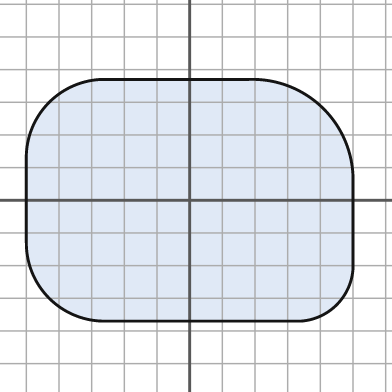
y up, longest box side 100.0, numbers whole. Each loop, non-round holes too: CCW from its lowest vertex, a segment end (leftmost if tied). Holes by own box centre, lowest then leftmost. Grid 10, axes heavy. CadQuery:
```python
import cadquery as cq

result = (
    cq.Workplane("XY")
    .moveTo(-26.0, -37.0)
    .lineTo(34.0, -37.0)
    .threePointArc((45.0, -32.0), (50.0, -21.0))
    .lineTo(50.0, 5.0)
    .threePointArc((41.0, 28.0), (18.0, 37.0))
    .lineTo(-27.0, 37.0)
    .threePointArc((-43.0, 30.0), (-50.0, 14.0))
    .lineTo(-50.0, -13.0)
    .threePointArc((-43.0, -30.0), (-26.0, -37.0))
    .close()
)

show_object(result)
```